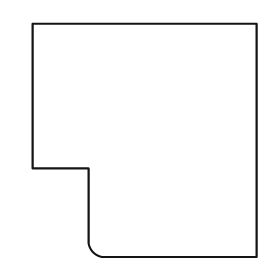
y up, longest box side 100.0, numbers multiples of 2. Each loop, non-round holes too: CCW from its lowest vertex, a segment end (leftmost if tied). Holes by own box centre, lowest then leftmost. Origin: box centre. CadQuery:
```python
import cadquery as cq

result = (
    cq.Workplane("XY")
    .moveTo(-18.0, -50.0)
    .lineTo(48.0, -50.0)
    .lineTo(48.0, 50.0)
    .lineTo(-48.0, 50.0)
    .lineTo(-48.0, -12.0)
    .lineTo(-24.0, -12.0)
    .lineTo(-24.0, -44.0)
    .threePointArc((-22.0, -48.0), (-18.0, -50.0))
    .close()
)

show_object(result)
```